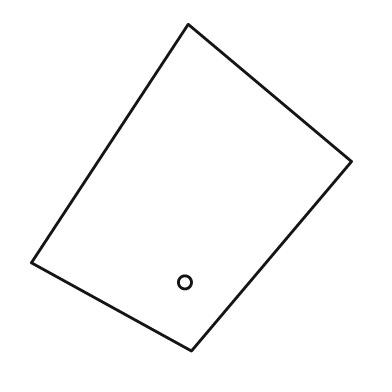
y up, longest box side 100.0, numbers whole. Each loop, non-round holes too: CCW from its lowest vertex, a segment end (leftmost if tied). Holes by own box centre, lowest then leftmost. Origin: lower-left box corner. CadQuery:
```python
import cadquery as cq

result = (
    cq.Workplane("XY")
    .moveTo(49.0, 0.0)
    .lineTo(98.0, 58.0)
    .lineTo(48.0, 100.0)
    .lineTo(0.0, 27.0)
    .close()
    .moveTo(47.0, 21.0)
    .circle(2.0)
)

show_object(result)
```